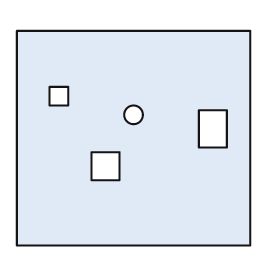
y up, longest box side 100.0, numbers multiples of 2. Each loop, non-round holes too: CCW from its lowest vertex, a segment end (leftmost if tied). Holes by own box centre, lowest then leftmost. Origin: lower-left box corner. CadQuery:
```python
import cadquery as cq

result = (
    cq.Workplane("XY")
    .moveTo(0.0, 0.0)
    .lineTo(100.0, 0.0)
    .lineTo(100.0, 92.0)
    .lineTo(0.0, 92.0)
    .close()
    .moveTo(32.0, 28.0)
    .lineTo(44.0, 28.0)
    .lineTo(44.0, 40.0)
    .lineTo(32.0, 40.0)
    .close()
    .moveTo(78.0, 42.0)
    .lineTo(90.0, 42.0)
    .lineTo(90.0, 58.0)
    .lineTo(78.0, 58.0)
    .close()
    .moveTo(50.0, 56.0)
    .circle(4.0)
    .moveTo(14.0, 60.0)
    .lineTo(22.0, 60.0)
    .lineTo(22.0, 68.0)
    .lineTo(14.0, 68.0)
    .close()
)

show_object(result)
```